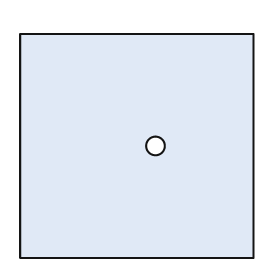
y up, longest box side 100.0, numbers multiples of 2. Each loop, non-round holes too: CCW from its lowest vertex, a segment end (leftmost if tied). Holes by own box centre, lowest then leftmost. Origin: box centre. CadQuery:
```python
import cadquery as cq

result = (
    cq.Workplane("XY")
    .moveTo(-50.0, -48.0)
    .lineTo(50.0, -48.0)
    .lineTo(50.0, 48.0)
    .lineTo(-50.0, 48.0)
    .close()
    .moveTo(8.0, 0.0)
    .circle(4.0)
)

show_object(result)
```